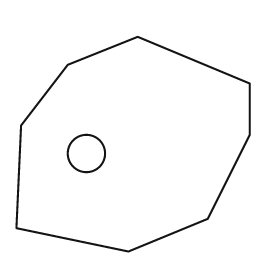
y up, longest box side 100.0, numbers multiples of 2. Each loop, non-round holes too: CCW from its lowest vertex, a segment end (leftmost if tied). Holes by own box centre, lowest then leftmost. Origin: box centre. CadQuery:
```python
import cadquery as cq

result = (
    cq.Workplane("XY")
    .moveTo(-2.0, -46.0)
    .lineTo(32.0, -32.0)
    .lineTo(50.0, 4.0)
    .lineTo(50.0, 26.0)
    .lineTo(2.0, 46.0)
    .lineTo(-28.0, 34.0)
    .lineTo(-48.0, 8.0)
    .lineTo(-50.0, -36.0)
    .close()
    .moveTo(-20.0, -4.0)
    .circle(8.0)
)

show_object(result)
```